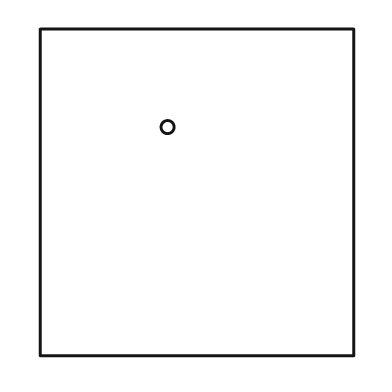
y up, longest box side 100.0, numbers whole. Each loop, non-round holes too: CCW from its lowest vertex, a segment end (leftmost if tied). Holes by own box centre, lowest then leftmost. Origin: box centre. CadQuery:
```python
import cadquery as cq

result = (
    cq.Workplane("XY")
    .moveTo(-48.0, -50.0)
    .lineTo(48.0, -50.0)
    .lineTo(48.0, 50.0)
    .lineTo(-48.0, 50.0)
    .close()
    .moveTo(-9.0, 20.0)
    .circle(2.0)
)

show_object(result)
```